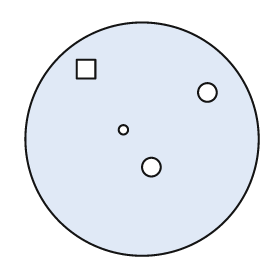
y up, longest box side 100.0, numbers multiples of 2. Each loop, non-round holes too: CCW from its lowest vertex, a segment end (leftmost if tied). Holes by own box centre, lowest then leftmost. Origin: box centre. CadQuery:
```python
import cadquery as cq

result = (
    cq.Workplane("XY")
    .moveTo(0.0, 0.0)
    .circle(50.0)
    .moveTo(4.0, -12.0)
    .circle(4.0)
    .moveTo(-8.0, 4.0)
    .circle(2.0)
    .moveTo(28.0, 20.0)
    .circle(4.0)
    .moveTo(-28.0, 26.0)
    .lineTo(-20.0, 26.0)
    .lineTo(-20.0, 34.0)
    .lineTo(-28.0, 34.0)
    .close()
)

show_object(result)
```